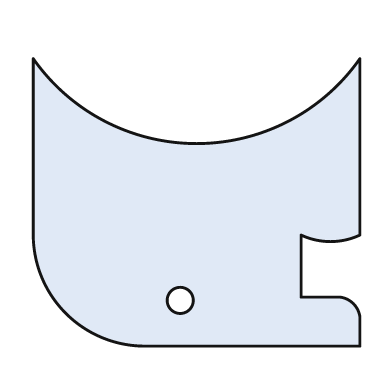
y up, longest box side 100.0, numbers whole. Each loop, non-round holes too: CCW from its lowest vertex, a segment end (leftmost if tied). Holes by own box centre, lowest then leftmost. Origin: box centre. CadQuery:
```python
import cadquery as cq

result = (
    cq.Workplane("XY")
    .moveTo(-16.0, -44.0)
    .lineTo(50.0, -44.0)
    .lineTo(50.0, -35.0)
    .threePointArc((48.0, -31.0), (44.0, -29.0))
    .lineTo(32.0, -29.0)
    .lineTo(32.0, -10.0)
    .threePointArc((41.0, -12.0), (50.0, -10.0))
    .lineTo(50.0, 44.0)
    .threePointArc((0.0, 18.0), (-50.0, 44.0))
    .lineTo(-50.0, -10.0)
    .threePointArc((-40.0, -34.0), (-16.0, -44.0))
    .close()
    .moveTo(-5.0, -30.0)
    .circle(4.0)
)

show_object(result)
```